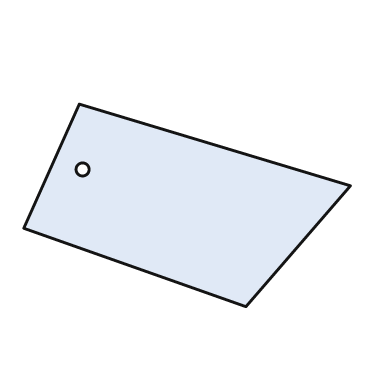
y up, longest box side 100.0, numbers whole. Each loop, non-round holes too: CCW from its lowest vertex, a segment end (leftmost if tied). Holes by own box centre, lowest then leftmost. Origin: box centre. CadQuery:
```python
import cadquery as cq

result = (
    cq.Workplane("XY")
    .moveTo(18.0, -31.0)
    .lineTo(50.0, 6.0)
    .lineTo(-33.0, 31.0)
    .lineTo(-50.0, -7.0)
    .close()
    .moveTo(-32.0, 11.0)
    .circle(2.0)
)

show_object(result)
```